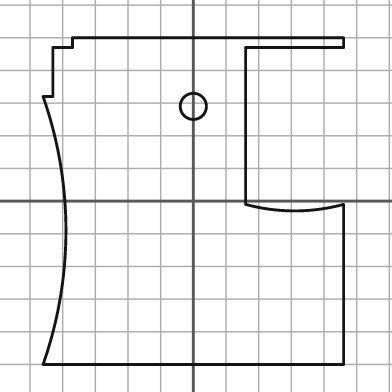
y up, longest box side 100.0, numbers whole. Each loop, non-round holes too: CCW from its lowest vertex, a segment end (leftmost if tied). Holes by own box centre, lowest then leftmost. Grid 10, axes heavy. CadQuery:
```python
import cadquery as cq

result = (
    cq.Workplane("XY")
    .moveTo(-46.0, -50.0)
    .lineTo(46.0, -50.0)
    .lineTo(46.0, -1.0)
    .threePointArc((31.0, -3.0), (16.0, -1.0))
    .lineTo(16.0, 47.0)
    .lineTo(46.0, 47.0)
    .lineTo(46.0, 50.0)
    .lineTo(-37.0, 50.0)
    .lineTo(-37.0, 47.0)
    .lineTo(-43.0, 47.0)
    .lineTo(-43.0, 32.0)
    .lineTo(-46.0, 32.0)
    .threePointArc((-39.0, -9.0), (-46.0, -50.0))
    .close()
    .moveTo(0.0, 29.0)
    .circle(4.0)
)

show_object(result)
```